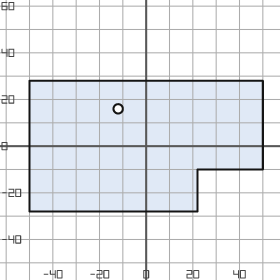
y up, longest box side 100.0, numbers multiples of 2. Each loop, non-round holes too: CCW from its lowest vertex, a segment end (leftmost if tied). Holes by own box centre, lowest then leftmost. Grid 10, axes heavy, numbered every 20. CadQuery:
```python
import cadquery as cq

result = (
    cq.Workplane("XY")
    .moveTo(-50.0, -28.0)
    .lineTo(22.0, -28.0)
    .lineTo(22.0, -10.0)
    .lineTo(50.0, -10.0)
    .lineTo(50.0, 28.0)
    .lineTo(-50.0, 28.0)
    .close()
    .moveTo(-12.0, 16.0)
    .circle(2.0)
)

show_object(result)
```